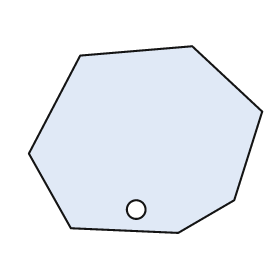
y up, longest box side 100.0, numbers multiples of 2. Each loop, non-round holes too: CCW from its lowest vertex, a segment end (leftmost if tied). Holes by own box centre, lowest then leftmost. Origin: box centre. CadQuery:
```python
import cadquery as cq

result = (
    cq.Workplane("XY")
    .moveTo(14.0, -40.0)
    .lineTo(38.0, -26.0)
    .lineTo(50.0, 12.0)
    .lineTo(20.0, 40.0)
    .lineTo(-28.0, 36.0)
    .lineTo(-50.0, -6.0)
    .lineTo(-32.0, -38.0)
    .close()
    .moveTo(-4.0, -30.0)
    .circle(4.0)
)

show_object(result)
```